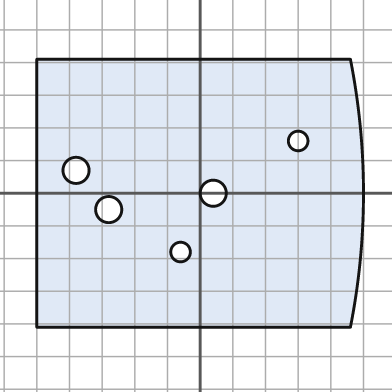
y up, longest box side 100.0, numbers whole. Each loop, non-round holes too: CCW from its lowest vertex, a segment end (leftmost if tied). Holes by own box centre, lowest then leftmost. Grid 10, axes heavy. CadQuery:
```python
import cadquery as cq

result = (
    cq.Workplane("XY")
    .moveTo(-50.0, -41.0)
    .lineTo(46.0, -41.0)
    .threePointArc((50.0, 0.0), (46.0, 41.0))
    .lineTo(-50.0, 41.0)
    .close()
    .moveTo(-6.0, -18.0)
    .circle(3.0)
    .moveTo(-28.0, -5.0)
    .circle(4.0)
    .moveTo(4.0, 0.0)
    .circle(4.0)
    .moveTo(-38.0, 7.0)
    .circle(4.0)
    .moveTo(30.0, 16.0)
    .circle(3.0)
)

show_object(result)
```